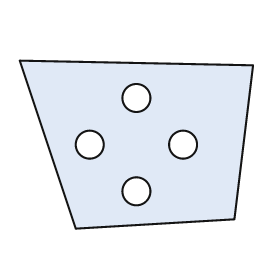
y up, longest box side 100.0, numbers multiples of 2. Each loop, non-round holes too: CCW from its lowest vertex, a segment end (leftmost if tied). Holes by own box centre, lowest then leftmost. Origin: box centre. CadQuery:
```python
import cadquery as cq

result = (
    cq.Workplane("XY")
    .moveTo(-26.0, -36.0)
    .lineTo(42.0, -32.0)
    .lineTo(50.0, 34.0)
    .lineTo(-50.0, 36.0)
    .close()
    .moveTo(0.0, -20.0)
    .circle(6.0)
    .moveTo(-20.0, 0.0)
    .circle(6.0)
    .moveTo(20.0, 0.0)
    .circle(6.0)
    .moveTo(0.0, 20.0)
    .circle(6.0)
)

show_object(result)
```